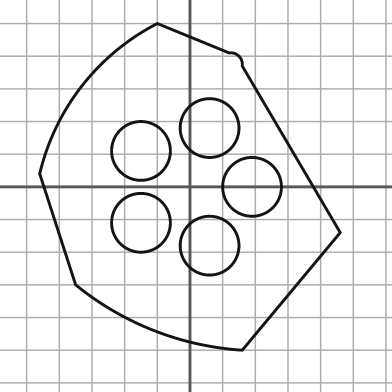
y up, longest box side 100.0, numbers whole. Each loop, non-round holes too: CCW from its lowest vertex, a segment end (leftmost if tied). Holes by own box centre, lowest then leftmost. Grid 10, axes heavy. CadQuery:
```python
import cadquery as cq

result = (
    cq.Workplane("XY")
    .moveTo(16.0, -50.0)
    .lineTo(46.0, -14.0)
    .lineTo(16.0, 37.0)
    .threePointArc((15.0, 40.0), (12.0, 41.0))
    .lineTo(-10.0, 50.0)
    .threePointArc((-33.0, 31.0), (-46.0, 4.0))
    .lineTo(-35.0, -30.0)
    .threePointArc((-11.0, -44.0), (16.0, -50.0))
    .close()
    .moveTo(6.0, -18.0)
    .circle(9.0)
    .moveTo(-15.0, -11.0)
    .circle(9.0)
    .moveTo(19.0, 0.0)
    .circle(9.0)
    .moveTo(-15.0, 11.0)
    .circle(9.0)
    .moveTo(6.0, 18.0)
    .circle(9.0)
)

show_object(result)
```